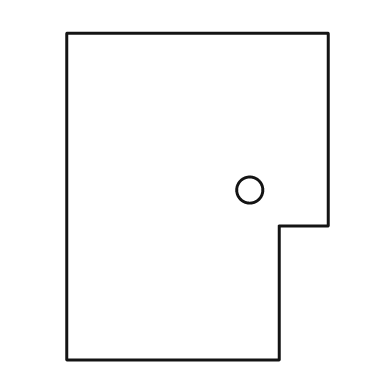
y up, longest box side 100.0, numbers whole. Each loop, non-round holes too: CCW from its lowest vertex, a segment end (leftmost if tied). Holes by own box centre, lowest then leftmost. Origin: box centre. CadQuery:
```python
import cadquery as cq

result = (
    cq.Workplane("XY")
    .moveTo(-40.0, -50.0)
    .lineTo(25.0, -50.0)
    .lineTo(25.0, -9.0)
    .lineTo(40.0, -9.0)
    .lineTo(40.0, 50.0)
    .lineTo(-40.0, 50.0)
    .close()
    .moveTo(16.0, 2.0)
    .circle(4.0)
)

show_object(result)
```